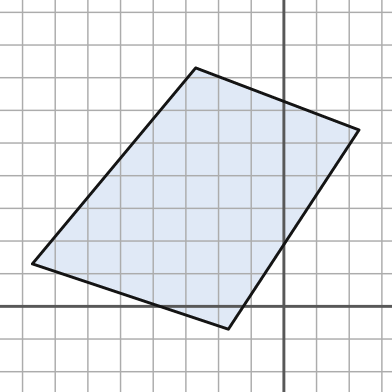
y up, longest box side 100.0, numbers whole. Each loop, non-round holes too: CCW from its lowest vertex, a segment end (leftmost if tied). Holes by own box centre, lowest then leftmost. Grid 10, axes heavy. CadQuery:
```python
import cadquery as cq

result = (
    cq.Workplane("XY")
    .moveTo(-17.0, -7.0)
    .lineTo(23.0, 54.0)
    .lineTo(-27.0, 73.0)
    .lineTo(-77.0, 13.0)
    .close()
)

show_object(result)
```